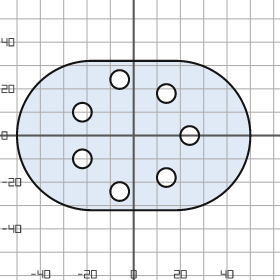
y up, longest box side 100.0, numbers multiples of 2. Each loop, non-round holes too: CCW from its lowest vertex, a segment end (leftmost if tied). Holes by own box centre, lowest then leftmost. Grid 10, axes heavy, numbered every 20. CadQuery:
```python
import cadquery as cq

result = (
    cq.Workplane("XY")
    .moveTo(-18.0, -32.0)
    .lineTo(18.0, -32.0)
    .threePointArc((50.0, 0.0), (18.0, 32.0))
    .lineTo(-18.0, 32.0)
    .threePointArc((-50.0, 0.0), (-18.0, -32.0))
    .close()
    .moveTo(-6.0, -24.0)
    .circle(4.0)
    .moveTo(14.0, -18.0)
    .circle(4.0)
    .moveTo(-22.0, -10.0)
    .circle(4.0)
    .moveTo(24.0, 0.0)
    .circle(4.0)
    .moveTo(-22.0, 10.0)
    .circle(4.0)
    .moveTo(14.0, 18.0)
    .circle(4.0)
    .moveTo(-6.0, 24.0)
    .circle(4.0)
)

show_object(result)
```